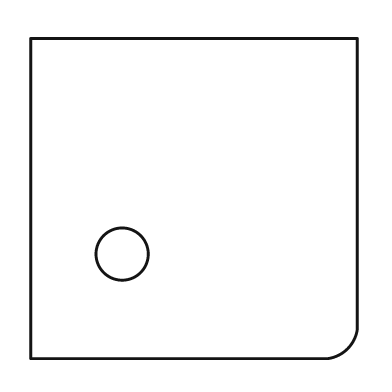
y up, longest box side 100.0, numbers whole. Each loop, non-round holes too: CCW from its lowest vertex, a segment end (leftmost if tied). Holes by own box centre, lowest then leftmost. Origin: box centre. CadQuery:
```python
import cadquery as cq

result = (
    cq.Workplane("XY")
    .moveTo(-50.0, -49.0)
    .lineTo(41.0, -49.0)
    .threePointArc((47.0, -46.0), (50.0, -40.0))
    .lineTo(50.0, 49.0)
    .lineTo(-50.0, 49.0)
    .close()
    .moveTo(-22.0, -17.0)
    .circle(8.0)
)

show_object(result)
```